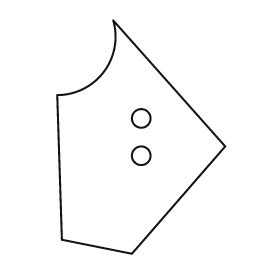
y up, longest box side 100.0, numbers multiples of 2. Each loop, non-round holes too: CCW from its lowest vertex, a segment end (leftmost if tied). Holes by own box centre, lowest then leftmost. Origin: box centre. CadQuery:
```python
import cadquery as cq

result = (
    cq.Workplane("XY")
    .moveTo(-4.0, -50.0)
    .lineTo(36.0, -4.0)
    .lineTo(-12.0, 50.0)
    .threePointArc((-16.0, 28.0), (-36.0, 18.0))
    .lineTo(-34.0, -44.0)
    .close()
    .moveTo(0.0, -8.0)
    .circle(4.0)
    .moveTo(0.0, 8.0)
    .circle(4.0)
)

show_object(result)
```